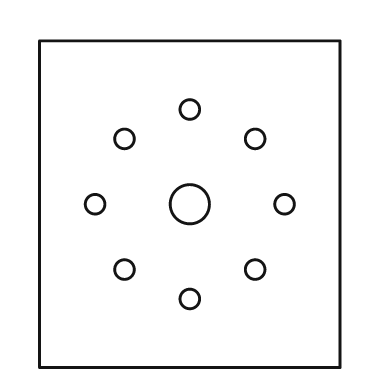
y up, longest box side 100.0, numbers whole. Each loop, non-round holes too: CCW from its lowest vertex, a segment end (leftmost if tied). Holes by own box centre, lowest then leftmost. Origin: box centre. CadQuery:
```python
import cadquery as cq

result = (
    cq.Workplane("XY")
    .moveTo(-46.0, -50.0)
    .lineTo(46.0, -50.0)
    .lineTo(46.0, 50.0)
    .lineTo(-46.0, 50.0)
    .close()
    .moveTo(0.0, -29.0)
    .circle(3.0)
    .moveTo(-20.0, -20.0)
    .circle(3.0)
    .moveTo(20.0, -20.0)
    .circle(3.0)
    .moveTo(-29.0, 0.0)
    .circle(3.0)
    .moveTo(0.0, 0.0)
    .circle(6.0)
    .moveTo(29.0, 0.0)
    .circle(3.0)
    .moveTo(-20.0, 20.0)
    .circle(3.0)
    .moveTo(20.0, 20.0)
    .circle(3.0)
    .moveTo(0.0, 29.0)
    .circle(3.0)
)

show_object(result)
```